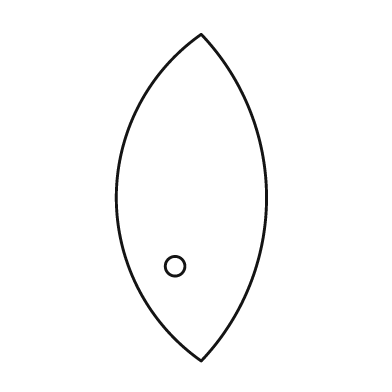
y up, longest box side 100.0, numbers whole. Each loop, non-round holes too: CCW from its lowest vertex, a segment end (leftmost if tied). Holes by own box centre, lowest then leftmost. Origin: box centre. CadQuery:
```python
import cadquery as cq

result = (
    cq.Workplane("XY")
    .moveTo(3.0, -50.0)
    .threePointArc((23.0, 0.0), (3.0, 50.0))
    .threePointArc((-23.0, 0.0), (3.0, -50.0))
    .close()
    .moveTo(-5.0, -21.0)
    .circle(3.0)
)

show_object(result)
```